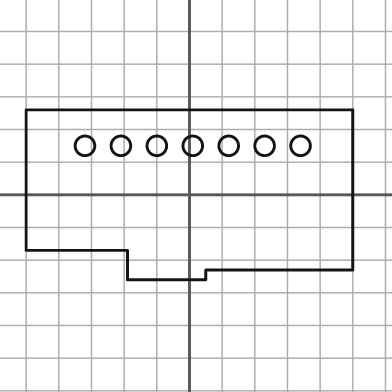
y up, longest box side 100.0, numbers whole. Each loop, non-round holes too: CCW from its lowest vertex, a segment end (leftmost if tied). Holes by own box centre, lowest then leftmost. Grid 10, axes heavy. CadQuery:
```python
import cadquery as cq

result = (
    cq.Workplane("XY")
    .moveTo(-19.0, -26.0)
    .lineTo(5.0, -26.0)
    .lineTo(5.0, -23.0)
    .lineTo(50.0, -23.0)
    .lineTo(50.0, 26.0)
    .lineTo(-50.0, 26.0)
    .lineTo(-50.0, -17.0)
    .lineTo(-19.0, -17.0)
    .close()
    .moveTo(-32.0, 15.0)
    .circle(3.0)
    .moveTo(-21.0, 15.0)
    .circle(3.0)
    .moveTo(-10.0, 15.0)
    .circle(3.0)
    .moveTo(1.0, 15.0)
    .circle(3.0)
    .moveTo(12.0, 15.0)
    .circle(3.0)
    .moveTo(23.0, 15.0)
    .circle(3.0)
    .moveTo(34.0, 15.0)
    .circle(3.0)
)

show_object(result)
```